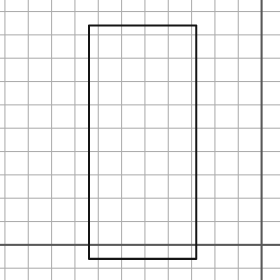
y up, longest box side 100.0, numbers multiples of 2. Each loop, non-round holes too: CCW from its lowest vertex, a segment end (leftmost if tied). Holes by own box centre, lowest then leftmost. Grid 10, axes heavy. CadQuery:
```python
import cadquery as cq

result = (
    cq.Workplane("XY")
    .moveTo(-74.0, -6.0)
    .lineTo(-28.0, -6.0)
    .lineTo(-28.0, 94.0)
    .lineTo(-74.0, 94.0)
    .close()
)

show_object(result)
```